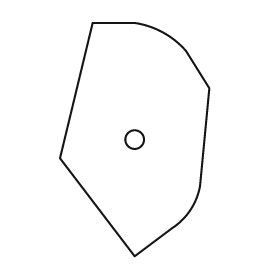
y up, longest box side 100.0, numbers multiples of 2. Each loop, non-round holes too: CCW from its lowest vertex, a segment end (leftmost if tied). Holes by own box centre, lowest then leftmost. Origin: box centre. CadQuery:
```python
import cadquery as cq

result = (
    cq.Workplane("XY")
    .moveTo(0.0, -50.0)
    .lineTo(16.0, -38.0)
    .threePointArc((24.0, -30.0), (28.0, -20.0))
    .lineTo(32.0, 22.0)
    .lineTo(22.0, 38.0)
    .threePointArc((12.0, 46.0), (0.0, 50.0))
    .lineTo(-18.0, 50.0)
    .lineTo(-32.0, -8.0)
    .close()
    .moveTo(0.0, 0.0)
    .circle(4.0)
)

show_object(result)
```